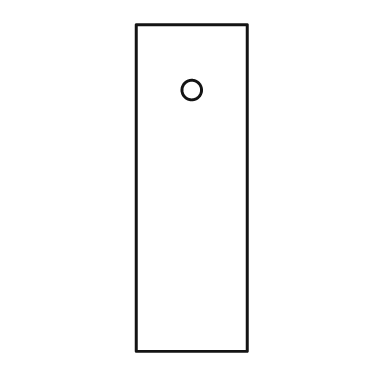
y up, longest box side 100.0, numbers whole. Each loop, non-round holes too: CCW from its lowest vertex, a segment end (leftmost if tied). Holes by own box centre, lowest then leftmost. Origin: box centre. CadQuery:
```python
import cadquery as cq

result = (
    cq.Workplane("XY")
    .moveTo(-17.0, -50.0)
    .lineTo(17.0, -50.0)
    .lineTo(17.0, 50.0)
    .lineTo(-17.0, 50.0)
    .close()
    .moveTo(0.0, 30.0)
    .circle(3.0)
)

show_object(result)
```